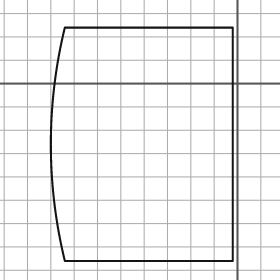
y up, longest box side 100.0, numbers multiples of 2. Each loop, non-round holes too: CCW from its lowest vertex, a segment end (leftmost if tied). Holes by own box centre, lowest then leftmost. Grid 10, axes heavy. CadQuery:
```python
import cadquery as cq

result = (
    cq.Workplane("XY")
    .moveTo(-74.0, -76.0)
    .lineTo(-2.0, -76.0)
    .lineTo(-2.0, 24.0)
    .lineTo(-74.0, 24.0)
    .threePointArc((-80.0, -26.0), (-74.0, -76.0))
    .close()
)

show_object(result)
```